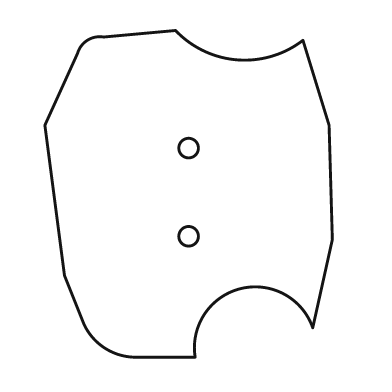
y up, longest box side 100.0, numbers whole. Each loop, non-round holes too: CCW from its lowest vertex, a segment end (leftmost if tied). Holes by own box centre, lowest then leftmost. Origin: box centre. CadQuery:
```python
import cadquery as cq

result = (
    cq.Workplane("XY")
    .moveTo(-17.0, -50.0)
    .lineTo(2.0, -50.0)
    .threePointArc((16.0, -29.0), (38.0, -41.0))
    .lineTo(44.0, -14.0)
    .lineTo(43.0, 21.0)
    .lineTo(35.0, 47.0)
    .threePointArc((15.0, 41.0), (-4.0, 50.0))
    .lineTo(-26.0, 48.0)
    .threePointArc((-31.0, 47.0), (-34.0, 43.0))
    .lineTo(-44.0, 21.0)
    .lineTo(-38.0, -25.0)
    .lineTo(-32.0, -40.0)
    .threePointArc((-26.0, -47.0), (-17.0, -50.0))
    .close()
    .moveTo(0.0, -13.0)
    .circle(3.0)
    .moveTo(0.0, 14.0)
    .circle(3.0)
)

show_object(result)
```